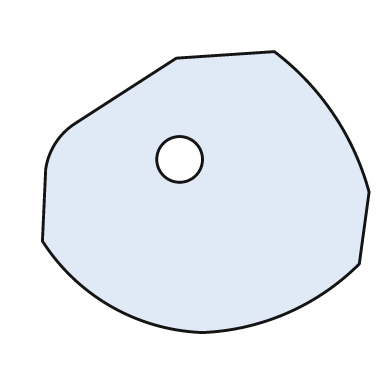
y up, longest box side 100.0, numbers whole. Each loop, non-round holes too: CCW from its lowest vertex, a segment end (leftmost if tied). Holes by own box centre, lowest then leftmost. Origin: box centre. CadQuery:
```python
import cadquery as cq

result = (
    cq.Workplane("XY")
    .moveTo(-1.0, -43.0)
    .threePointArc((25.0, -37.0), (47.0, -22.0))
    .lineTo(50.0, 0.0)
    .threePointArc((39.0, 24.0), (21.0, 43.0))
    .lineTo(-9.0, 41.0)
    .lineTo(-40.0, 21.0)
    .threePointArc((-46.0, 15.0), (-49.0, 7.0))
    .lineTo(-50.0, -15.0)
    .threePointArc((-29.0, -35.0), (-1.0, -43.0))
    .close()
    .moveTo(-8.0, 10.0)
    .circle(7.0)
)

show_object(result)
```